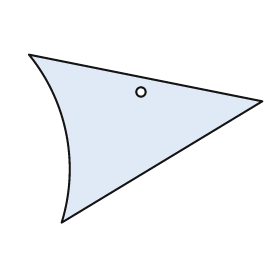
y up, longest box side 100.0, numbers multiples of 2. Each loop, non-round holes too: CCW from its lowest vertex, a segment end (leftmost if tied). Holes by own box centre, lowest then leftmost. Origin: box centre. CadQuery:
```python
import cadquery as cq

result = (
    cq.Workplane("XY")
    .moveTo(-36.0, -36.0)
    .lineTo(50.0, 16.0)
    .lineTo(-50.0, 36.0)
    .threePointArc((-34.0, 2.0), (-36.0, -36.0))
    .close()
    .moveTo(-2.0, 20.0)
    .circle(2.0)
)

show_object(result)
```